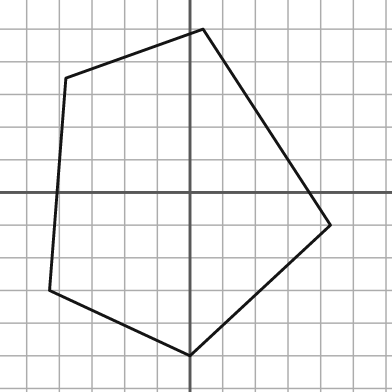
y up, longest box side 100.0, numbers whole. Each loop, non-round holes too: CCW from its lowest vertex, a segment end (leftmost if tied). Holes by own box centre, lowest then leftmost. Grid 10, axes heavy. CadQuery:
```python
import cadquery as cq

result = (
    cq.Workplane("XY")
    .moveTo(0.0, -50.0)
    .lineTo(43.0, -10.0)
    .lineTo(4.0, 50.0)
    .lineTo(-38.0, 35.0)
    .lineTo(-43.0, -30.0)
    .close()
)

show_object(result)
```